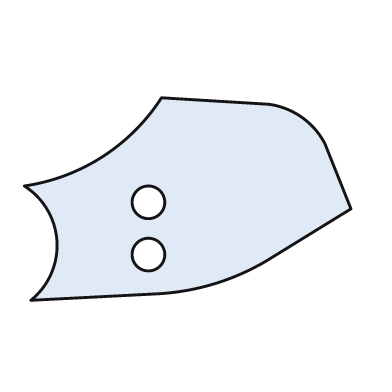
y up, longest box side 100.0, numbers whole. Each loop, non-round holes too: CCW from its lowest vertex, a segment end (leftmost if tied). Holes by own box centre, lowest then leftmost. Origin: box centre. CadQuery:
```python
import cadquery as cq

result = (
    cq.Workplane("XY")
    .moveTo(-48.0, -31.0)
    .lineTo(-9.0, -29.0)
    .threePointArc((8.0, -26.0), (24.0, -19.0))
    .lineTo(50.0, -3.0)
    .lineTo(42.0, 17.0)
    .threePointArc((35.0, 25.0), (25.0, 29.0))
    .lineTo(-8.0, 31.0)
    .threePointArc((-26.0, 13.0), (-50.0, 4.0))
    .threePointArc((-40.0, -13.0), (-48.0, -31.0))
    .close()
    .moveTo(-12.0, -17.0)
    .circle(5.0)
    .moveTo(-12.0, -1.0)
    .circle(5.0)
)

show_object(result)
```